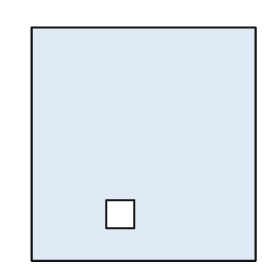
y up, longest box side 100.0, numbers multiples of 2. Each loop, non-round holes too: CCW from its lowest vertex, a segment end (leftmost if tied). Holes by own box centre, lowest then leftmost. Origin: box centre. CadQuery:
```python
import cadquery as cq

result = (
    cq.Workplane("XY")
    .moveTo(-48.0, -50.0)
    .lineTo(48.0, -50.0)
    .lineTo(48.0, 50.0)
    .lineTo(-48.0, 50.0)
    .close()
    .moveTo(-16.0, -36.0)
    .lineTo(-4.0, -36.0)
    .lineTo(-4.0, -24.0)
    .lineTo(-16.0, -24.0)
    .close()
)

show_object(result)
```